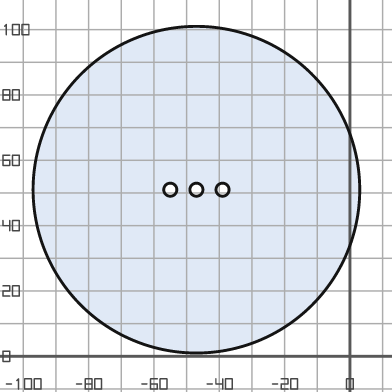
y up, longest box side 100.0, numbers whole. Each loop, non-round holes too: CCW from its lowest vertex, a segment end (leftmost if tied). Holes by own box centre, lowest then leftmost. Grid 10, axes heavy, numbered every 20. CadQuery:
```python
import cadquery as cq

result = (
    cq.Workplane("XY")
    .moveTo(-47.0, 51.0)
    .circle(50.0)
    .moveTo(-55.0, 51.0)
    .circle(2.0)
    .moveTo(-47.0, 51.0)
    .circle(2.0)
    .moveTo(-39.0, 51.0)
    .circle(2.0)
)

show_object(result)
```